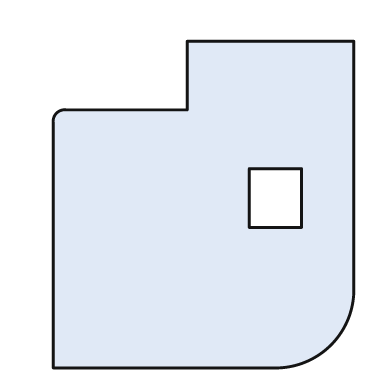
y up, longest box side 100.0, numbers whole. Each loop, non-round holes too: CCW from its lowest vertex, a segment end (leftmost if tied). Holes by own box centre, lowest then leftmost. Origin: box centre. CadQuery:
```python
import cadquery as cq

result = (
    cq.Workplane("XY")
    .moveTo(-46.0, -50.0)
    .lineTo(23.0, -50.0)
    .threePointArc((39.0, -43.0), (46.0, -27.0))
    .lineTo(46.0, 50.0)
    .lineTo(-5.0, 50.0)
    .lineTo(-5.0, 29.0)
    .lineTo(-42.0, 29.0)
    .threePointArc((-45.0, 28.0), (-46.0, 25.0))
    .close()
    .moveTo(14.0, -7.0)
    .lineTo(30.0, -7.0)
    .lineTo(30.0, 11.0)
    .lineTo(14.0, 11.0)
    .close()
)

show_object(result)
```